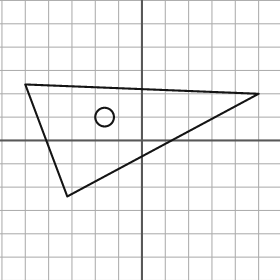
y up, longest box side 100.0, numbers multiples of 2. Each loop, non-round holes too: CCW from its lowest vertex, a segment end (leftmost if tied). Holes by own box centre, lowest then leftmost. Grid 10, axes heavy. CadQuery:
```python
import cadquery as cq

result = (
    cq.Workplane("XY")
    .moveTo(-32.0, -24.0)
    .lineTo(50.0, 20.0)
    .lineTo(-50.0, 24.0)
    .close()
    .moveTo(-16.0, 10.0)
    .circle(4.0)
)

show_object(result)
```